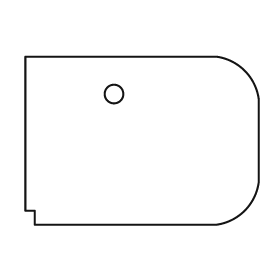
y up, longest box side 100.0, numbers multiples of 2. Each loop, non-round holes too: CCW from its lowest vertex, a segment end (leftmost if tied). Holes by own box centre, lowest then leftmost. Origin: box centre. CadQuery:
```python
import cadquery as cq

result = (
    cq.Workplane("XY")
    .moveTo(-46.0, -36.0)
    .lineTo(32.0, -36.0)
    .threePointArc((44.0, -30.0), (50.0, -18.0))
    .lineTo(50.0, 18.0)
    .threePointArc((44.0, 30.0), (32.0, 36.0))
    .lineTo(-50.0, 36.0)
    .lineTo(-50.0, -30.0)
    .lineTo(-46.0, -30.0)
    .close()
    .moveTo(-12.0, 20.0)
    .circle(4.0)
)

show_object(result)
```